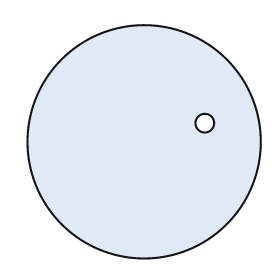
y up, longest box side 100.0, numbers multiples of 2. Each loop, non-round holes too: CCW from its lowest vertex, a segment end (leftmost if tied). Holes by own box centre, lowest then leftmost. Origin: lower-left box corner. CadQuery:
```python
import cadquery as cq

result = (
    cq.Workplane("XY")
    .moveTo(50.0, 50.0)
    .circle(50.0)
    .moveTo(76.0, 58.0)
    .circle(4.0)
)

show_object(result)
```